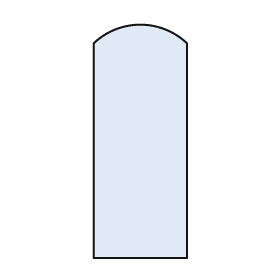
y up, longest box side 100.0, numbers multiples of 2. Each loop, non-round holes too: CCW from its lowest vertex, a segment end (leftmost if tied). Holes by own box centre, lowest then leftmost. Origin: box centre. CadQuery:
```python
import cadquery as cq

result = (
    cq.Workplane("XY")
    .moveTo(-20.0, -50.0)
    .lineTo(20.0, -50.0)
    .lineTo(20.0, 42.0)
    .threePointArc((0.0, 50.0), (-20.0, 42.0))
    .close()
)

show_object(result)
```